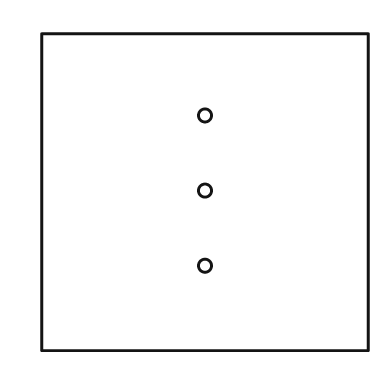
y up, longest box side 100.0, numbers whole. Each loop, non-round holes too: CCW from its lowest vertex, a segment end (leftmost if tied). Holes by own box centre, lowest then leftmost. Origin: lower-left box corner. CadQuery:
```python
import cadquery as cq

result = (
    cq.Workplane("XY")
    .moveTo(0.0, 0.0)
    .lineTo(100.0, 0.0)
    .lineTo(100.0, 97.0)
    .lineTo(0.0, 97.0)
    .close()
    .moveTo(50.0, 26.0)
    .circle(2.0)
    .moveTo(50.0, 49.0)
    .circle(2.0)
    .moveTo(50.0, 72.0)
    .circle(2.0)
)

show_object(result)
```